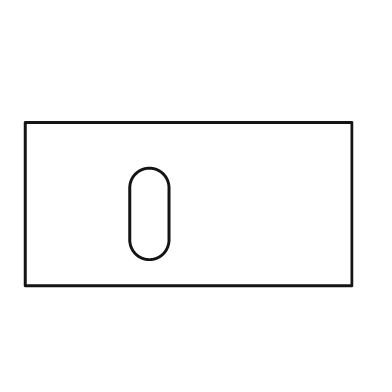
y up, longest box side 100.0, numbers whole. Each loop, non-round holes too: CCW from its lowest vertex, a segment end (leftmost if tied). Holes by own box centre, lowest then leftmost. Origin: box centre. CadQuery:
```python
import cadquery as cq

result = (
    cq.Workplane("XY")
    .moveTo(-50.0, -25.0)
    .lineTo(50.0, -25.0)
    .lineTo(50.0, 25.0)
    .lineTo(-50.0, 25.0)
    .close()
    .moveTo(-18.0, -11.0)
    .threePointArc((-12.0, -17.0), (-6.0, -11.0))
    .lineTo(-6.0, 5.0)
    .threePointArc((-12.0, 11.0), (-18.0, 5.0))
    .close()
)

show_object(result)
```